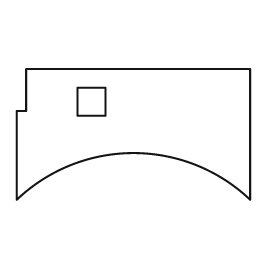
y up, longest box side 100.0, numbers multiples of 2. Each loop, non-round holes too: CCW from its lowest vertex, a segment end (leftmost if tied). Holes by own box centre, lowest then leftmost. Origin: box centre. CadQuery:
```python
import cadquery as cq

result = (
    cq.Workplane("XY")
    .moveTo(-50.0, -28.0)
    .threePointArc((0.0, -8.0), (50.0, -28.0))
    .lineTo(50.0, 28.0)
    .lineTo(-46.0, 28.0)
    .lineTo(-46.0, 10.0)
    .lineTo(-50.0, 10.0)
    .close()
    .moveTo(-24.0, 8.0)
    .lineTo(-12.0, 8.0)
    .lineTo(-12.0, 20.0)
    .lineTo(-24.0, 20.0)
    .close()
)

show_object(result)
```